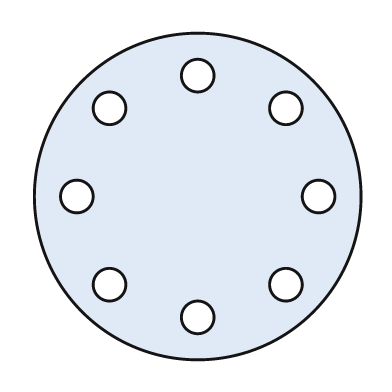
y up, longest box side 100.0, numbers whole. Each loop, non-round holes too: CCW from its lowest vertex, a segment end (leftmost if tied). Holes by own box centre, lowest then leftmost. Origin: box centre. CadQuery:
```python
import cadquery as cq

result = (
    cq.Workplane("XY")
    .moveTo(0.0, 0.0)
    .circle(50.0)
    .moveTo(0.0, -37.0)
    .circle(5.0)
    .moveTo(-27.0, -27.0)
    .circle(5.0)
    .moveTo(27.0, -27.0)
    .circle(5.0)
    .moveTo(-37.0, 0.0)
    .circle(5.0)
    .moveTo(37.0, 0.0)
    .circle(5.0)
    .moveTo(-27.0, 27.0)
    .circle(5.0)
    .moveTo(27.0, 27.0)
    .circle(5.0)
    .moveTo(0.0, 37.0)
    .circle(5.0)
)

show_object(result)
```